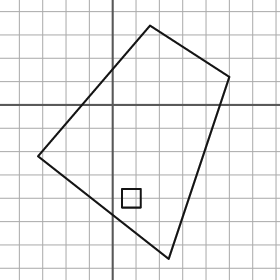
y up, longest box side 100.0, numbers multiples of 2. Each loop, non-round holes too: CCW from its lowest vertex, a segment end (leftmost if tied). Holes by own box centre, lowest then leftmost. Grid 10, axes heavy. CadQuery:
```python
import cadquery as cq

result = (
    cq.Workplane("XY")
    .moveTo(24.0, -66.0)
    .lineTo(50.0, 12.0)
    .lineTo(16.0, 34.0)
    .lineTo(-32.0, -22.0)
    .close()
    .moveTo(4.0, -44.0)
    .lineTo(12.0, -44.0)
    .lineTo(12.0, -36.0)
    .lineTo(4.0, -36.0)
    .close()
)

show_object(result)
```